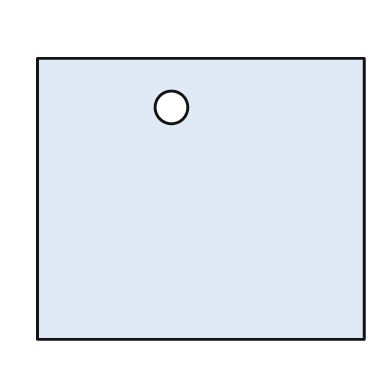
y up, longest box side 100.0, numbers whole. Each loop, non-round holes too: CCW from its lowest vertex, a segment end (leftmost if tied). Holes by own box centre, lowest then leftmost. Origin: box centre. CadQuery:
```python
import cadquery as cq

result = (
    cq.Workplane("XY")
    .moveTo(-50.0, -43.0)
    .lineTo(50.0, -43.0)
    .lineTo(50.0, 43.0)
    .lineTo(-50.0, 43.0)
    .close()
    .moveTo(-9.0, 28.0)
    .circle(5.0)
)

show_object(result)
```